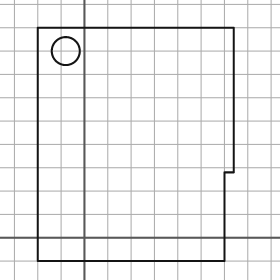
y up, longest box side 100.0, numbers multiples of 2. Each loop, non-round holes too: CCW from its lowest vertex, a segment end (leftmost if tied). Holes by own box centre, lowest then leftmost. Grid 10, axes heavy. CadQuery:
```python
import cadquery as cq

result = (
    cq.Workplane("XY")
    .moveTo(-20.0, -10.0)
    .lineTo(60.0, -10.0)
    .lineTo(60.0, 28.0)
    .lineTo(64.0, 28.0)
    .lineTo(64.0, 90.0)
    .lineTo(-20.0, 90.0)
    .close()
    .moveTo(-8.0, 80.0)
    .circle(6.0)
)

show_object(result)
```